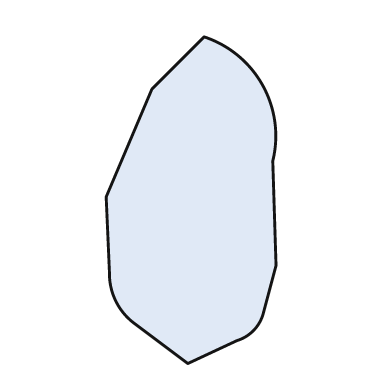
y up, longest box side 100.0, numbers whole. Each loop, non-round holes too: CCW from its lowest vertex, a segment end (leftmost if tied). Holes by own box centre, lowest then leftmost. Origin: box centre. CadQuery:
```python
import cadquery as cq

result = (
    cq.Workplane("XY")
    .moveTo(-1.0, -50.0)
    .lineTo(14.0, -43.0)
    .threePointArc((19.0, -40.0), (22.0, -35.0))
    .lineTo(26.0, -20.0)
    .lineTo(25.0, 12.0)
    .threePointArc((22.0, 35.0), (4.0, 50.0))
    .lineTo(-12.0, 34.0)
    .lineTo(-26.0, 1.0)
    .lineTo(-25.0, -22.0)
    .threePointArc((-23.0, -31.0), (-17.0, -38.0))
    .close()
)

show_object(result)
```